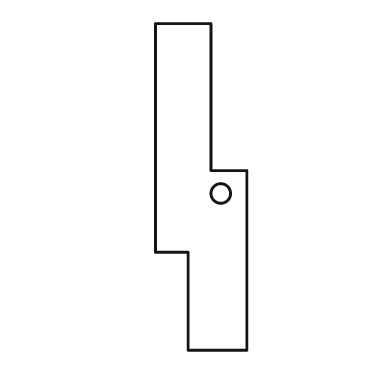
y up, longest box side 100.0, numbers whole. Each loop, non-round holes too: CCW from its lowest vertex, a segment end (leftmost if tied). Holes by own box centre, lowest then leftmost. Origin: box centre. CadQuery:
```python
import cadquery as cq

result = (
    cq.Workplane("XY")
    .moveTo(-4.0, -50.0)
    .lineTo(14.0, -50.0)
    .lineTo(14.0, 5.0)
    .lineTo(3.0, 5.0)
    .lineTo(3.0, 50.0)
    .lineTo(-14.0, 50.0)
    .lineTo(-14.0, -20.0)
    .lineTo(-4.0, -20.0)
    .close()
    .moveTo(6.0, -2.0)
    .circle(3.0)
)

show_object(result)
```